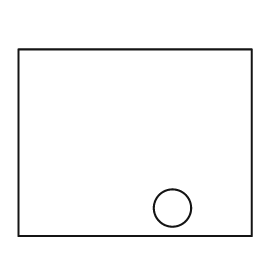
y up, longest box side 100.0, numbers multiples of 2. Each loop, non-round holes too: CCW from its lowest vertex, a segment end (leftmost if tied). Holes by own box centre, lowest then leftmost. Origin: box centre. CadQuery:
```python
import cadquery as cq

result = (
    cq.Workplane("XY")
    .moveTo(-50.0, -40.0)
    .lineTo(50.0, -40.0)
    .lineTo(50.0, 40.0)
    .lineTo(-50.0, 40.0)
    .close()
    .moveTo(16.0, -28.0)
    .circle(8.0)
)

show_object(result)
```